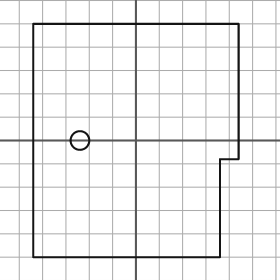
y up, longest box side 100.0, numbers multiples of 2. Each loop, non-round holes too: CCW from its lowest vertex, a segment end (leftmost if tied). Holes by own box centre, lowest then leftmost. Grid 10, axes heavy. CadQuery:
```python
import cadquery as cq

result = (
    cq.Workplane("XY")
    .moveTo(-44.0, -50.0)
    .lineTo(36.0, -50.0)
    .lineTo(36.0, -8.0)
    .lineTo(44.0, -8.0)
    .lineTo(44.0, 50.0)
    .lineTo(-44.0, 50.0)
    .close()
    .moveTo(-24.0, 0.0)
    .circle(4.0)
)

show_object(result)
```